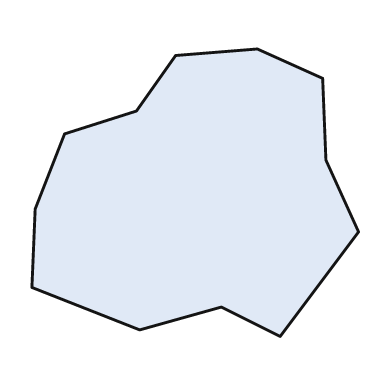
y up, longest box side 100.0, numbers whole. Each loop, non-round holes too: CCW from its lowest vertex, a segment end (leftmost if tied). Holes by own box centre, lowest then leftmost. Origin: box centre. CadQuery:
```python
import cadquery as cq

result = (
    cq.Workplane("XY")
    .moveTo(26.0, -44.0)
    .lineTo(50.0, -12.0)
    .lineTo(40.0, 10.0)
    .lineTo(39.0, 35.0)
    .lineTo(19.0, 44.0)
    .lineTo(-6.0, 42.0)
    .lineTo(-18.0, 25.0)
    .lineTo(-40.0, 18.0)
    .lineTo(-49.0, -5.0)
    .lineTo(-50.0, -29.0)
    .lineTo(-17.0, -42.0)
    .lineTo(8.0, -35.0)
    .close()
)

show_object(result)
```